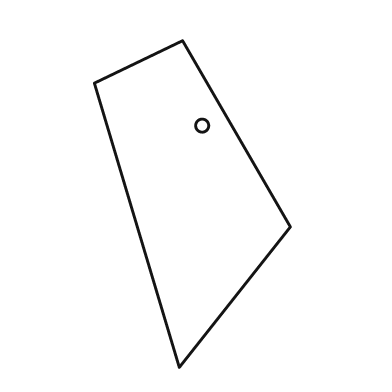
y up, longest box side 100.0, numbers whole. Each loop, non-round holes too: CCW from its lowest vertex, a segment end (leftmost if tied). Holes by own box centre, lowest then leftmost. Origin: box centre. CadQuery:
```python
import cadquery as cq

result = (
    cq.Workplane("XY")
    .moveTo(-4.0, -50.0)
    .lineTo(30.0, -7.0)
    .lineTo(-3.0, 50.0)
    .lineTo(-30.0, 37.0)
    .close()
    .moveTo(3.0, 24.0)
    .circle(2.0)
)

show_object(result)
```